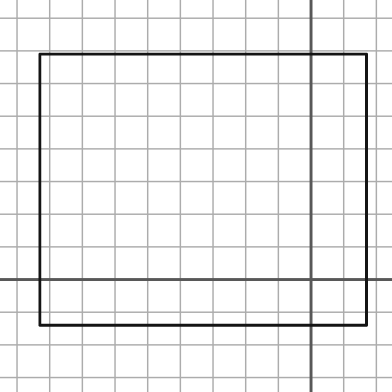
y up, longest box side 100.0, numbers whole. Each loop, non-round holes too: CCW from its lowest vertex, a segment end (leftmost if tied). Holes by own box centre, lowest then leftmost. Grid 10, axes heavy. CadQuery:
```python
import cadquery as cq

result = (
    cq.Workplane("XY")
    .moveTo(-83.0, -14.0)
    .lineTo(17.0, -14.0)
    .lineTo(17.0, 69.0)
    .lineTo(-83.0, 69.0)
    .close()
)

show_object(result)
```